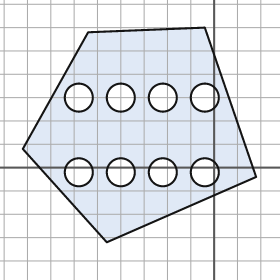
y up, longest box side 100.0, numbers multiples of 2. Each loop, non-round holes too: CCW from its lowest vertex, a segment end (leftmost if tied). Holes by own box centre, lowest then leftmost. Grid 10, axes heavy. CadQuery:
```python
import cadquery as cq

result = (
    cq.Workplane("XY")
    .moveTo(-46.0, -32.0)
    .lineTo(18.0, -4.0)
    .lineTo(-4.0, 60.0)
    .lineTo(-54.0, 58.0)
    .lineTo(-82.0, 8.0)
    .close()
    .moveTo(-58.0, -2.0)
    .circle(6.0)
    .moveTo(-40.0, -2.0)
    .circle(6.0)
    .moveTo(-22.0, -2.0)
    .circle(6.0)
    .moveTo(-4.0, -2.0)
    .circle(6.0)
    .moveTo(-58.0, 30.0)
    .circle(6.0)
    .moveTo(-40.0, 30.0)
    .circle(6.0)
    .moveTo(-22.0, 30.0)
    .circle(6.0)
    .moveTo(-4.0, 30.0)
    .circle(6.0)
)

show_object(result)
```